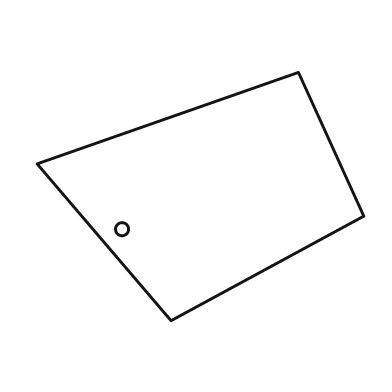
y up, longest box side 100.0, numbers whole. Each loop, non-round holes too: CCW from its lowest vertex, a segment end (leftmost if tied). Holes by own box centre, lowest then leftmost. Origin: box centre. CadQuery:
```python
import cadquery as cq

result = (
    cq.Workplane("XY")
    .moveTo(-9.0, -38.0)
    .lineTo(50.0, -6.0)
    .lineTo(30.0, 38.0)
    .lineTo(-50.0, 10.0)
    .close()
    .moveTo(-24.0, -10.0)
    .circle(2.0)
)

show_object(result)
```